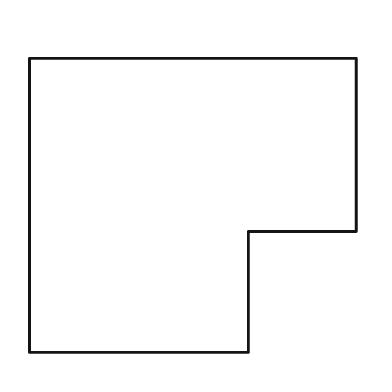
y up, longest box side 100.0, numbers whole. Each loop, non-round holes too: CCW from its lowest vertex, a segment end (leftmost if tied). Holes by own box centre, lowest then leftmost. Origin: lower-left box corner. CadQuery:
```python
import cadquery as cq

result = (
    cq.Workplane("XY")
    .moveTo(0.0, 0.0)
    .lineTo(67.0, 0.0)
    .lineTo(67.0, 37.0)
    .lineTo(100.0, 37.0)
    .lineTo(100.0, 90.0)
    .lineTo(0.0, 90.0)
    .close()
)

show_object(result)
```